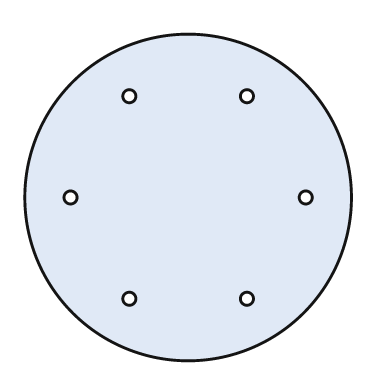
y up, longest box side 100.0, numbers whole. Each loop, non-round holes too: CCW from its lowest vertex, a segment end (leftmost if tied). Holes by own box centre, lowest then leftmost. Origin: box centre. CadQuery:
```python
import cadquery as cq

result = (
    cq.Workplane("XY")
    .moveTo(0.0, 0.0)
    .circle(50.0)
    .moveTo(-18.0, -31.0)
    .circle(2.0)
    .moveTo(18.0, -31.0)
    .circle(2.0)
    .moveTo(-36.0, 0.0)
    .circle(2.0)
    .moveTo(36.0, 0.0)
    .circle(2.0)
    .moveTo(-18.0, 31.0)
    .circle(2.0)
    .moveTo(18.0, 31.0)
    .circle(2.0)
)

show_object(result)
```